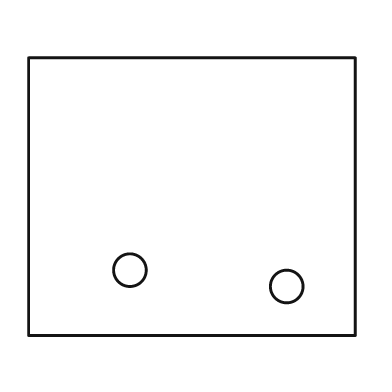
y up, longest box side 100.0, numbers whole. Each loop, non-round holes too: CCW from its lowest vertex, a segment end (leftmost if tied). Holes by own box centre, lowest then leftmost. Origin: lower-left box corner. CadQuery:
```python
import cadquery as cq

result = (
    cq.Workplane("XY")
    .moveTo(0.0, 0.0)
    .lineTo(100.0, 0.0)
    .lineTo(100.0, 85.0)
    .lineTo(0.0, 85.0)
    .close()
    .moveTo(79.0, 15.0)
    .circle(5.0)
    .moveTo(31.0, 20.0)
    .circle(5.0)
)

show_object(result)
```